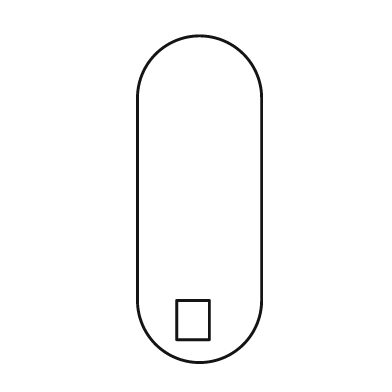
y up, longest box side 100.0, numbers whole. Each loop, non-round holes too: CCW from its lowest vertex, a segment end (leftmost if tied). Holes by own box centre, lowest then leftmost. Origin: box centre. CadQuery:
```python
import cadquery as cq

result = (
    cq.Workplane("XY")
    .moveTo(-19.0, -31.0)
    .threePointArc((0.0, -50.0), (19.0, -31.0))
    .lineTo(19.0, 31.0)
    .threePointArc((0.0, 50.0), (-19.0, 31.0))
    .close()
    .moveTo(-7.0, -43.0)
    .lineTo(3.0, -43.0)
    .lineTo(3.0, -31.0)
    .lineTo(-7.0, -31.0)
    .close()
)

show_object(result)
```